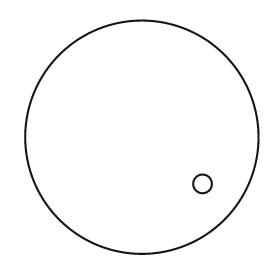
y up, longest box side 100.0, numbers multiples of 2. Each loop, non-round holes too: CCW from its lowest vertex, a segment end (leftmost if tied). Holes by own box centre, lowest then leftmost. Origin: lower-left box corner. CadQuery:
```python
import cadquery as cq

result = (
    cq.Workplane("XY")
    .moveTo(50.0, 50.0)
    .circle(50.0)
    .moveTo(76.0, 30.0)
    .circle(4.0)
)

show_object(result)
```